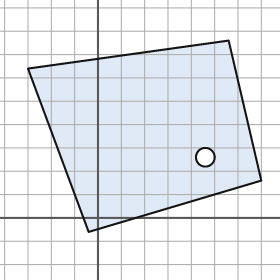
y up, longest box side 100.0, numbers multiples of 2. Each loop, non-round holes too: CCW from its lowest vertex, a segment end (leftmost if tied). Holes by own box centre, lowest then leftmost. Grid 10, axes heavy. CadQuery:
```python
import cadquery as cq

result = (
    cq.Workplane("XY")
    .moveTo(-4.0, -6.0)
    .lineTo(70.0, 16.0)
    .lineTo(56.0, 76.0)
    .lineTo(-30.0, 64.0)
    .close()
    .moveTo(46.0, 26.0)
    .circle(4.0)
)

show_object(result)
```